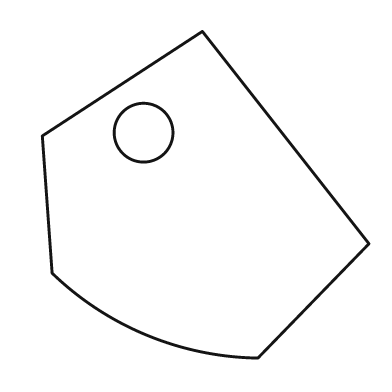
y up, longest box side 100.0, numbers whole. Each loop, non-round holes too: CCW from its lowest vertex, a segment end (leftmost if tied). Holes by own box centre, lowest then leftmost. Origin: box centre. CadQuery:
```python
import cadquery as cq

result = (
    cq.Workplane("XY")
    .moveTo(16.0, -50.0)
    .lineTo(50.0, -15.0)
    .lineTo(-1.0, 50.0)
    .lineTo(-50.0, 18.0)
    .lineTo(-47.0, -24.0)
    .threePointArc((-18.0, -43.0), (16.0, -50.0))
    .close()
    .moveTo(-19.0, 19.0)
    .circle(9.0)
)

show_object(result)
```